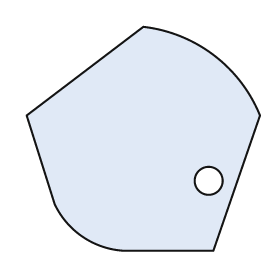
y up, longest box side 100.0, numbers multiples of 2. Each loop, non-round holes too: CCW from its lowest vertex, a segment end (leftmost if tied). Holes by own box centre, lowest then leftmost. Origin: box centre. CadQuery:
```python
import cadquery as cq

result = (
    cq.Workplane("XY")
    .moveTo(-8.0, -48.0)
    .lineTo(30.0, -48.0)
    .lineTo(50.0, 10.0)
    .threePointArc((30.0, 36.0), (0.0, 48.0))
    .lineTo(-50.0, 10.0)
    .lineTo(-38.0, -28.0)
    .threePointArc((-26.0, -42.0), (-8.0, -48.0))
    .close()
    .moveTo(28.0, -18.0)
    .circle(6.0)
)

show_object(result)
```